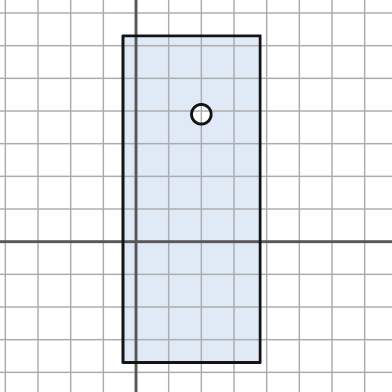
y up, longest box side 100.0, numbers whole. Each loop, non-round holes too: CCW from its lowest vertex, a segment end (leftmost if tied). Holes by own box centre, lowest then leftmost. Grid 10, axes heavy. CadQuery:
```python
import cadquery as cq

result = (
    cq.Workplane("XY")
    .moveTo(-4.0, -37.0)
    .lineTo(38.0, -37.0)
    .lineTo(38.0, 63.0)
    .lineTo(-4.0, 63.0)
    .close()
    .moveTo(20.0, 39.0)
    .circle(3.0)
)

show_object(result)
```